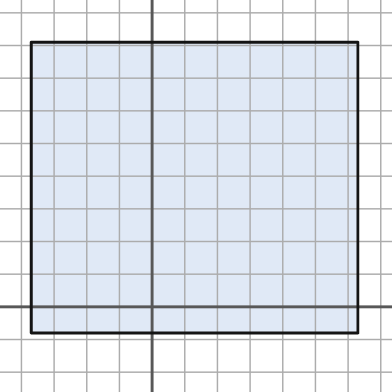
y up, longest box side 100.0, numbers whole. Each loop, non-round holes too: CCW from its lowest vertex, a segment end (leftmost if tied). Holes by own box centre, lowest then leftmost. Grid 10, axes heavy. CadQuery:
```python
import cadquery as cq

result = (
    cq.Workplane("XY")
    .moveTo(-37.0, -8.0)
    .lineTo(63.0, -8.0)
    .lineTo(63.0, 81.0)
    .lineTo(-37.0, 81.0)
    .close()
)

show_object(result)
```